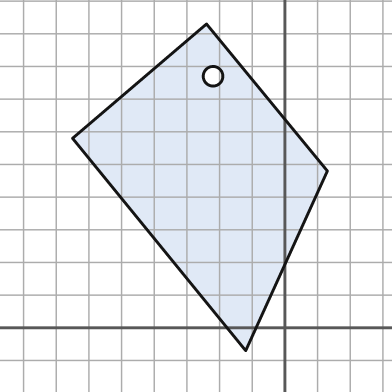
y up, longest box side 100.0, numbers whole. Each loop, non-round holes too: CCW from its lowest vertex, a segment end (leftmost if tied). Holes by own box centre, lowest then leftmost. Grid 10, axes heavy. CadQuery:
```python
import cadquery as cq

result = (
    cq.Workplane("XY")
    .moveTo(-12.0, -7.0)
    .lineTo(13.0, 48.0)
    .lineTo(-24.0, 93.0)
    .lineTo(-65.0, 58.0)
    .close()
    .moveTo(-22.0, 77.0)
    .circle(3.0)
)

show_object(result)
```